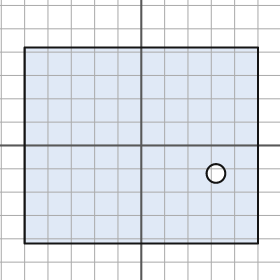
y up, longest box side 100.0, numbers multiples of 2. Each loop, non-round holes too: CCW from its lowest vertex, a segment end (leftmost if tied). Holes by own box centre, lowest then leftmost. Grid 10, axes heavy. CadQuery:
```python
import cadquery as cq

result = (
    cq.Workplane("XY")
    .moveTo(-50.0, -42.0)
    .lineTo(50.0, -42.0)
    .lineTo(50.0, 42.0)
    .lineTo(-50.0, 42.0)
    .close()
    .moveTo(32.0, -12.0)
    .circle(4.0)
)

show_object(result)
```